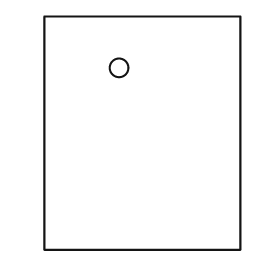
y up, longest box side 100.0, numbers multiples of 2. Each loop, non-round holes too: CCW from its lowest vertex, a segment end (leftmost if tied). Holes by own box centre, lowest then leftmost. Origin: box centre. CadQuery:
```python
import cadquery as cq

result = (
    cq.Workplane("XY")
    .moveTo(-42.0, -50.0)
    .lineTo(42.0, -50.0)
    .lineTo(42.0, 50.0)
    .lineTo(-42.0, 50.0)
    .close()
    .moveTo(-10.0, 28.0)
    .circle(4.0)
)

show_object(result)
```